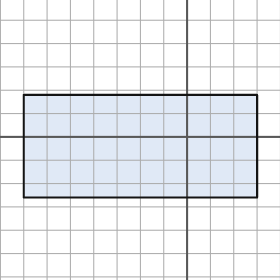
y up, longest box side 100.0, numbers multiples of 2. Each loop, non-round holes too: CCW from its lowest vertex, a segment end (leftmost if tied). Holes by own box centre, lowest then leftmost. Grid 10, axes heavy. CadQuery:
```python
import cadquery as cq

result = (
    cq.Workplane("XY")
    .moveTo(-70.0, -26.0)
    .lineTo(30.0, -26.0)
    .lineTo(30.0, 18.0)
    .lineTo(-70.0, 18.0)
    .close()
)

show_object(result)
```